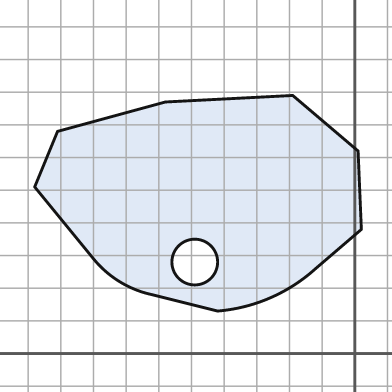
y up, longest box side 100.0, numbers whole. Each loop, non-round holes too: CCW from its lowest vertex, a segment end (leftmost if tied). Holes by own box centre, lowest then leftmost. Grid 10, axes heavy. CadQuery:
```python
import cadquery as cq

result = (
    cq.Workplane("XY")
    .moveTo(-42.0, 13.0)
    .threePointArc((-26.0, 17.0), (-12.0, 26.0))
    .lineTo(2.0, 38.0)
    .lineTo(1.0, 62.0)
    .lineTo(-19.0, 79.0)
    .lineTo(-58.0, 77.0)
    .lineTo(-91.0, 68.0)
    .lineTo(-98.0, 51.0)
    .lineTo(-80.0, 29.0)
    .threePointArc((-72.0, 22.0), (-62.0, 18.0))
    .close()
    .moveTo(-49.0, 28.0)
    .circle(7.0)
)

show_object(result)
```